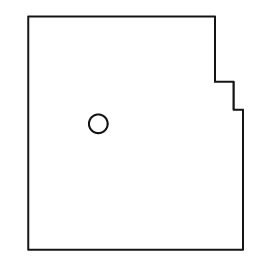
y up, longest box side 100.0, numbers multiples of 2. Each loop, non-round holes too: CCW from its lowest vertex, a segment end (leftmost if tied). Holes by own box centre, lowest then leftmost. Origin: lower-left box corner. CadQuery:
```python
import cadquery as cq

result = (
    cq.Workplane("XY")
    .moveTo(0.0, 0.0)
    .lineTo(92.0, 0.0)
    .lineTo(92.0, 60.0)
    .lineTo(88.0, 60.0)
    .lineTo(88.0, 72.0)
    .lineTo(80.0, 72.0)
    .lineTo(80.0, 100.0)
    .lineTo(0.0, 100.0)
    .close()
    .moveTo(30.0, 54.0)
    .circle(4.0)
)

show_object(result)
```